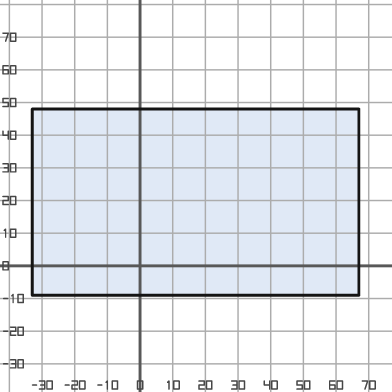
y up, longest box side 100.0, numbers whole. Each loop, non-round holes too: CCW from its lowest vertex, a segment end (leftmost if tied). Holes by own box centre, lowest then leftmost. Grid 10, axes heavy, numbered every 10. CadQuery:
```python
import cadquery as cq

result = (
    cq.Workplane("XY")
    .moveTo(-33.0, -9.0)
    .lineTo(67.0, -9.0)
    .lineTo(67.0, 48.0)
    .lineTo(-33.0, 48.0)
    .close()
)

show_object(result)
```